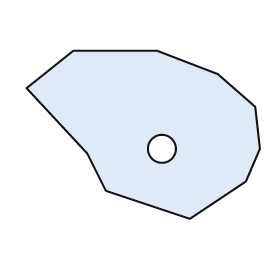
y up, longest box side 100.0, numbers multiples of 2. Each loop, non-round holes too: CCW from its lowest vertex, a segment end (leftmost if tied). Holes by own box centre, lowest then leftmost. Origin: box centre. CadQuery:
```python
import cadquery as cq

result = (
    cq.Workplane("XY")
    .moveTo(20.0, -36.0)
    .lineTo(44.0, -20.0)
    .lineTo(50.0, -6.0)
    .lineTo(48.0, 12.0)
    .lineTo(32.0, 26.0)
    .lineTo(6.0, 36.0)
    .lineTo(-30.0, 36.0)
    .lineTo(-50.0, 20.0)
    .lineTo(-24.0, -8.0)
    .lineTo(-16.0, -24.0)
    .close()
    .moveTo(8.0, -6.0)
    .circle(6.0)
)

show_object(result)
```